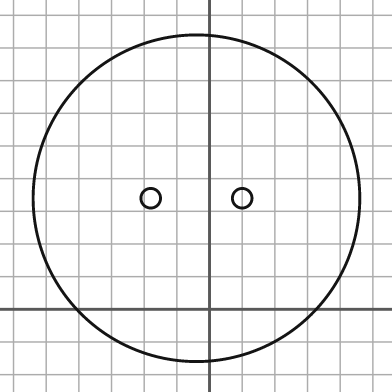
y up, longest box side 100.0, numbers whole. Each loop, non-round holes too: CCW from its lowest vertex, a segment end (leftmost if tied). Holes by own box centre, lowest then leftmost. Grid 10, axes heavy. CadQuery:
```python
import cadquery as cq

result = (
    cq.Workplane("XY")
    .moveTo(-4.0, 34.0)
    .circle(50.0)
    .moveTo(-18.0, 34.0)
    .circle(3.0)
    .moveTo(10.0, 34.0)
    .circle(3.0)
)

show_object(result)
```